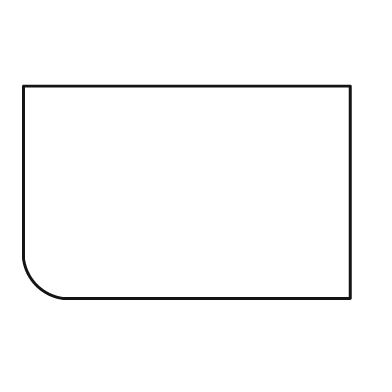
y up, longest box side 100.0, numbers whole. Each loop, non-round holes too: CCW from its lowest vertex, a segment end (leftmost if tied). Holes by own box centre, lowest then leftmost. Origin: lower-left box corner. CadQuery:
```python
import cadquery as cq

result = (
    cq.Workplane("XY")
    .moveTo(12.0, 0.0)
    .lineTo(100.0, 0.0)
    .lineTo(100.0, 65.0)
    .lineTo(0.0, 65.0)
    .lineTo(0.0, 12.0)
    .threePointArc((4.0, 4.0), (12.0, 0.0))
    .close()
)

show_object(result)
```